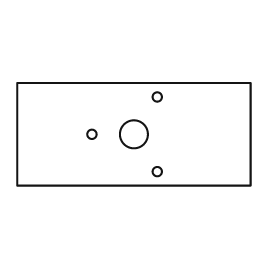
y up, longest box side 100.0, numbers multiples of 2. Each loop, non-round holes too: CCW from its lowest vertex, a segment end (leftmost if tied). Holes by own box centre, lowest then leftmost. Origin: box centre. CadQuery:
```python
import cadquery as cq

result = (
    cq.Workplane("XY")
    .moveTo(-50.0, -22.0)
    .lineTo(50.0, -22.0)
    .lineTo(50.0, 22.0)
    .lineTo(-50.0, 22.0)
    .close()
    .moveTo(10.0, -16.0)
    .circle(2.0)
    .moveTo(-18.0, 0.0)
    .circle(2.0)
    .moveTo(0.0, 0.0)
    .circle(6.0)
    .moveTo(10.0, 16.0)
    .circle(2.0)
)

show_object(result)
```